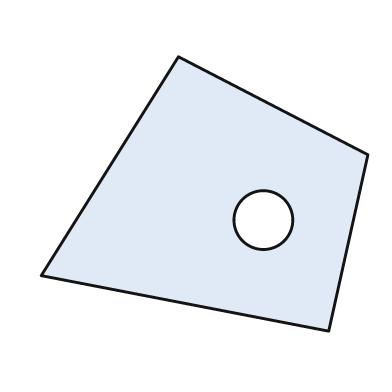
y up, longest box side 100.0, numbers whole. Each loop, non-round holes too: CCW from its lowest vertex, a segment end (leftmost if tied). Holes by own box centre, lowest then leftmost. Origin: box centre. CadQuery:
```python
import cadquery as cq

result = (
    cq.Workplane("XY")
    .moveTo(38.0, -42.0)
    .lineTo(50.0, 12.0)
    .lineTo(-8.0, 42.0)
    .lineTo(-50.0, -25.0)
    .close()
    .moveTo(18.0, -8.0)
    .circle(9.0)
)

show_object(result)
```